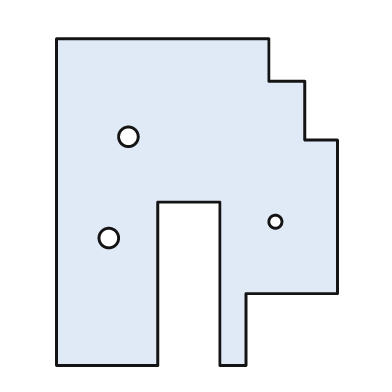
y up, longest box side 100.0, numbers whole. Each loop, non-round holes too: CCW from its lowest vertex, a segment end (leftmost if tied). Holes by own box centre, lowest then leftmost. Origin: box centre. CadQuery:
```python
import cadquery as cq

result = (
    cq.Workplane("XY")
    .moveTo(-43.0, -50.0)
    .lineTo(-12.0, -50.0)
    .lineTo(-12.0, 0.0)
    .lineTo(7.0, 0.0)
    .lineTo(7.0, -50.0)
    .lineTo(15.0, -50.0)
    .lineTo(15.0, -28.0)
    .lineTo(43.0, -28.0)
    .lineTo(43.0, 19.0)
    .lineTo(33.0, 19.0)
    .lineTo(33.0, 37.0)
    .lineTo(22.0, 37.0)
    .lineTo(22.0, 50.0)
    .lineTo(-43.0, 50.0)
    .close()
    .moveTo(-27.0, -11.0)
    .circle(3.0)
    .moveTo(24.0, -6.0)
    .circle(2.0)
    .moveTo(-21.0, 20.0)
    .circle(3.0)
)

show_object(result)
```